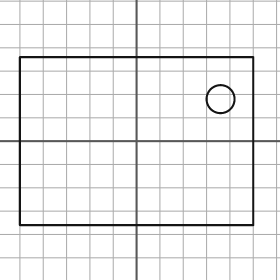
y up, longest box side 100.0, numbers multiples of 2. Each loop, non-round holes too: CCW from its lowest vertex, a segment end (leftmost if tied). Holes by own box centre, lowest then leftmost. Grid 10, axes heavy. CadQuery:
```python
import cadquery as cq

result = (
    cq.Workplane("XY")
    .moveTo(-50.0, -36.0)
    .lineTo(50.0, -36.0)
    .lineTo(50.0, 36.0)
    .lineTo(-50.0, 36.0)
    .close()
    .moveTo(36.0, 18.0)
    .circle(6.0)
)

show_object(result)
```